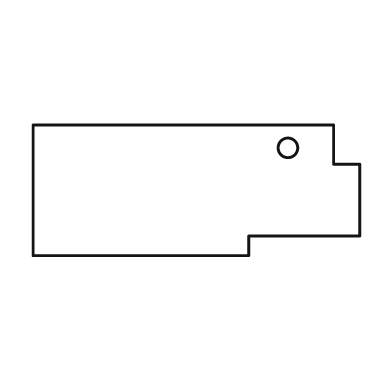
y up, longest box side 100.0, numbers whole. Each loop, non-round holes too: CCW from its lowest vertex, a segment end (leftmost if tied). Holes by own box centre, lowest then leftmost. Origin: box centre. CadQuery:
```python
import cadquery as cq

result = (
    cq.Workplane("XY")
    .moveTo(-50.0, -20.0)
    .lineTo(16.0, -20.0)
    .lineTo(16.0, -14.0)
    .lineTo(50.0, -14.0)
    .lineTo(50.0, 8.0)
    .lineTo(42.0, 8.0)
    .lineTo(42.0, 20.0)
    .lineTo(-50.0, 20.0)
    .close()
    .moveTo(28.0, 13.0)
    .circle(3.0)
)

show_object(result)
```